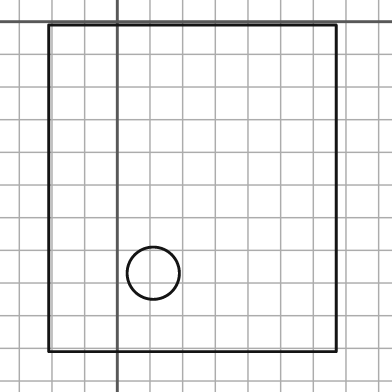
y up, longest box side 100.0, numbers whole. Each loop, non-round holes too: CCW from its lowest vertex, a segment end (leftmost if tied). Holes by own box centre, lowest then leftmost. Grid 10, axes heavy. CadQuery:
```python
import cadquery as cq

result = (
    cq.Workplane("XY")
    .moveTo(-21.0, -101.0)
    .lineTo(67.0, -101.0)
    .lineTo(67.0, -1.0)
    .lineTo(-21.0, -1.0)
    .close()
    .moveTo(11.0, -77.0)
    .circle(8.0)
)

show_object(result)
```